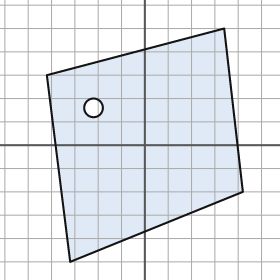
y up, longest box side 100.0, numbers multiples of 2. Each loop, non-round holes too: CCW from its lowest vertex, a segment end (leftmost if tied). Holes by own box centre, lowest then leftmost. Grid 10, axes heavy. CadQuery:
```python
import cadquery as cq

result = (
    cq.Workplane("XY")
    .moveTo(-32.0, -50.0)
    .lineTo(42.0, -20.0)
    .lineTo(34.0, 50.0)
    .lineTo(-42.0, 30.0)
    .close()
    .moveTo(-22.0, 16.0)
    .circle(4.0)
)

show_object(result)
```